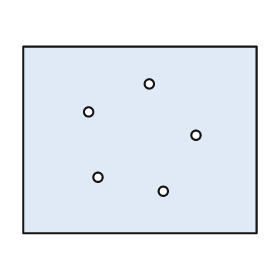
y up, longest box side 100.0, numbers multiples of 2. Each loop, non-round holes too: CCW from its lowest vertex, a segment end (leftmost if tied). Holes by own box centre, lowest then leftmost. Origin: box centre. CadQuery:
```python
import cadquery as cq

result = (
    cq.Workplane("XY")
    .moveTo(-50.0, -40.0)
    .lineTo(50.0, -40.0)
    .lineTo(50.0, 40.0)
    .lineTo(-50.0, 40.0)
    .close()
    .moveTo(10.0, -22.0)
    .circle(2.0)
    .moveTo(-18.0, -16.0)
    .circle(2.0)
    .moveTo(24.0, 2.0)
    .circle(2.0)
    .moveTo(-22.0, 12.0)
    .circle(2.0)
    .moveTo(4.0, 24.0)
    .circle(2.0)
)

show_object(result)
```